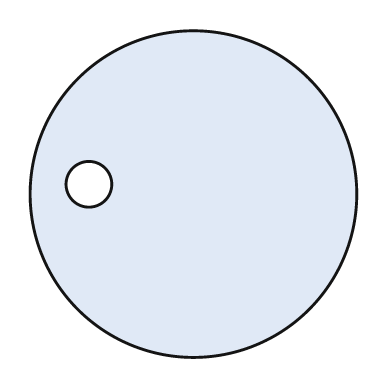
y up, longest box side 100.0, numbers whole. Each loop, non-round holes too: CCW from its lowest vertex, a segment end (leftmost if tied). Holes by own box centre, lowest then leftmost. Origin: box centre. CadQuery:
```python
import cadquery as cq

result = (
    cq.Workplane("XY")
    .moveTo(0.0, 0.0)
    .circle(50.0)
    .moveTo(-32.0, 3.0)
    .circle(7.0)
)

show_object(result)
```